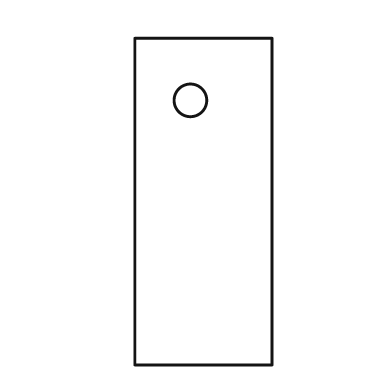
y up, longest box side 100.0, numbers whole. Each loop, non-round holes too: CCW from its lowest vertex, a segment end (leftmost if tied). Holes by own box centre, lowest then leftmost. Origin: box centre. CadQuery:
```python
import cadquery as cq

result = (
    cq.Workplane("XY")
    .moveTo(-21.0, -50.0)
    .lineTo(21.0, -50.0)
    .lineTo(21.0, 50.0)
    .lineTo(-21.0, 50.0)
    .close()
    .moveTo(-4.0, 31.0)
    .circle(5.0)
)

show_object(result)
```